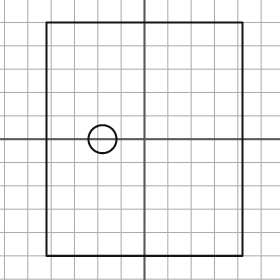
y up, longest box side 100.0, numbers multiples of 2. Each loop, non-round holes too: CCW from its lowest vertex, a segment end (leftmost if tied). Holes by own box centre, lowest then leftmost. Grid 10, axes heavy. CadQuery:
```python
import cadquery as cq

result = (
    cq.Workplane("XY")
    .moveTo(-42.0, -50.0)
    .lineTo(42.0, -50.0)
    .lineTo(42.0, 50.0)
    .lineTo(-42.0, 50.0)
    .close()
    .moveTo(-18.0, 0.0)
    .circle(6.0)
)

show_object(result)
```